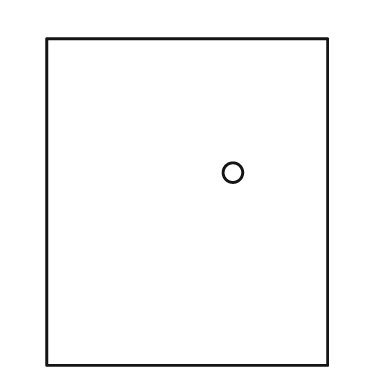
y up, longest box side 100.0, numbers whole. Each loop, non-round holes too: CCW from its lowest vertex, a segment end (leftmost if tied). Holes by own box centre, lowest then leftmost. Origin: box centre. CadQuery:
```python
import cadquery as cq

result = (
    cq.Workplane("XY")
    .moveTo(-43.0, -50.0)
    .lineTo(43.0, -50.0)
    .lineTo(43.0, 50.0)
    .lineTo(-43.0, 50.0)
    .close()
    .moveTo(14.0, 9.0)
    .circle(3.0)
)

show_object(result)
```